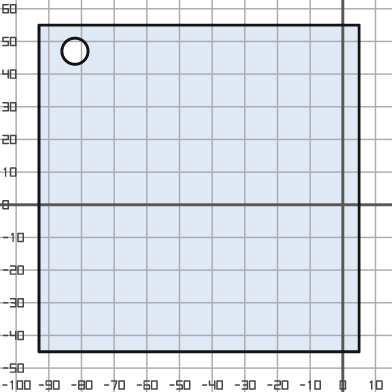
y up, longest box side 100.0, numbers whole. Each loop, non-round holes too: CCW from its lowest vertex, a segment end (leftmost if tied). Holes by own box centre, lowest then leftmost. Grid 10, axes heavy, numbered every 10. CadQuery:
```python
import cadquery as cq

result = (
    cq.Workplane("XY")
    .moveTo(-93.0, -45.0)
    .lineTo(5.0, -45.0)
    .lineTo(5.0, 55.0)
    .lineTo(-93.0, 55.0)
    .close()
    .moveTo(-82.0, 47.0)
    .circle(4.0)
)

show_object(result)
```